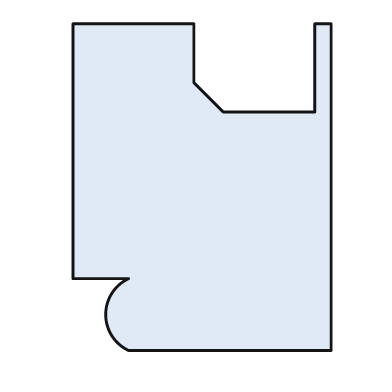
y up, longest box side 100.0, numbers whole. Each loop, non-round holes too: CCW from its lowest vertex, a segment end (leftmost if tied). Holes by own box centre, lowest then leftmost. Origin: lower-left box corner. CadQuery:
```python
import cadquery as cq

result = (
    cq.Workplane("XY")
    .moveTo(17.0, 0.0)
    .lineTo(79.0, 0.0)
    .lineTo(79.0, 100.0)
    .lineTo(74.0, 100.0)
    .lineTo(74.0, 73.0)
    .lineTo(46.0, 73.0)
    .lineTo(37.0, 82.0)
    .lineTo(37.0, 100.0)
    .lineTo(0.0, 100.0)
    .lineTo(0.0, 22.0)
    .lineTo(17.0, 22.0)
    .threePointArc((10.0, 11.0), (17.0, 0.0))
    .close()
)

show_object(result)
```